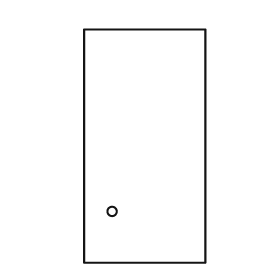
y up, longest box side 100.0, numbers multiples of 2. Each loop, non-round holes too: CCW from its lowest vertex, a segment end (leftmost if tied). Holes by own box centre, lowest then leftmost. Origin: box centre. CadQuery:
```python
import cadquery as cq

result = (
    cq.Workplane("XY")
    .moveTo(-26.0, -50.0)
    .lineTo(26.0, -50.0)
    .lineTo(26.0, 50.0)
    .lineTo(-26.0, 50.0)
    .close()
    .moveTo(-14.0, -28.0)
    .circle(2.0)
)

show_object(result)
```